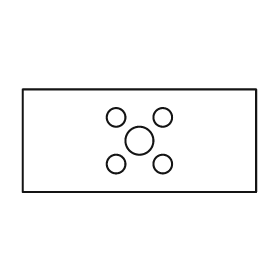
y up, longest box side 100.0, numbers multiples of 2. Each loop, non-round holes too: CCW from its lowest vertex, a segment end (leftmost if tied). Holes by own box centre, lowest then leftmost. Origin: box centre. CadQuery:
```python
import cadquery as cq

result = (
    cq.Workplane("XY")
    .moveTo(-50.0, -22.0)
    .lineTo(50.0, -22.0)
    .lineTo(50.0, 22.0)
    .lineTo(-50.0, 22.0)
    .close()
    .moveTo(-10.0, -10.0)
    .circle(4.0)
    .moveTo(10.0, -10.0)
    .circle(4.0)
    .moveTo(0.0, 0.0)
    .circle(6.0)
    .moveTo(-10.0, 10.0)
    .circle(4.0)
    .moveTo(10.0, 10.0)
    .circle(4.0)
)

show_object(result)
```